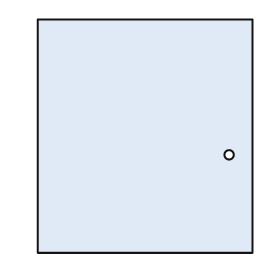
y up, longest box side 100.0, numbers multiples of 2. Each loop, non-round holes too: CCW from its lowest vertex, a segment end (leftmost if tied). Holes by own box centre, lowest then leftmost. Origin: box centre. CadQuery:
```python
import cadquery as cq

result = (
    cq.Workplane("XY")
    .moveTo(-46.0, -50.0)
    .lineTo(46.0, -50.0)
    .lineTo(46.0, 50.0)
    .lineTo(-46.0, 50.0)
    .close()
    .moveTo(36.0, -8.0)
    .circle(2.0)
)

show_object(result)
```